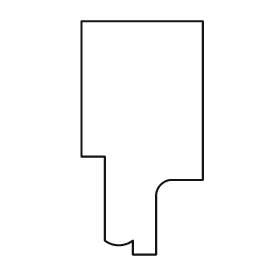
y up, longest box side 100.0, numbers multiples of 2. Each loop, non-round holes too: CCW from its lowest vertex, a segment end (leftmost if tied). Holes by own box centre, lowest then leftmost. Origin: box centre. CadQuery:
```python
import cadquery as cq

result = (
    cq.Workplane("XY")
    .moveTo(-4.0, -50.0)
    .lineTo(6.0, -50.0)
    .lineTo(6.0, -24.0)
    .threePointArc((8.0, -20.0), (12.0, -18.0))
    .lineTo(26.0, -18.0)
    .lineTo(26.0, 50.0)
    .lineTo(-26.0, 50.0)
    .lineTo(-26.0, -8.0)
    .lineTo(-16.0, -8.0)
    .lineTo(-16.0, -44.0)
    .threePointArc((-10.0, -46.0), (-4.0, -44.0))
    .close()
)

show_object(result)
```